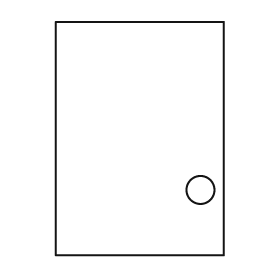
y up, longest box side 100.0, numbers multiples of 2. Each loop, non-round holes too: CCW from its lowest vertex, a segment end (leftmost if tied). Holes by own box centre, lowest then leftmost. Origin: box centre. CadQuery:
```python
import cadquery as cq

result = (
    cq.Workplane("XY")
    .moveTo(-36.0, -50.0)
    .lineTo(36.0, -50.0)
    .lineTo(36.0, 50.0)
    .lineTo(-36.0, 50.0)
    .close()
    .moveTo(26.0, -22.0)
    .circle(6.0)
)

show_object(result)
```